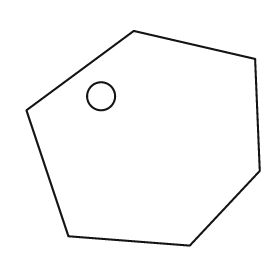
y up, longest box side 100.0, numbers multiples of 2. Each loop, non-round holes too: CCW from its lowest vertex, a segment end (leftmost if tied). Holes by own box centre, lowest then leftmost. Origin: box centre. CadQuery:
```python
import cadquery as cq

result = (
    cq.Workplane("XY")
    .moveTo(20.0, -46.0)
    .lineTo(50.0, -14.0)
    .lineTo(48.0, 34.0)
    .lineTo(-4.0, 46.0)
    .lineTo(-50.0, 12.0)
    .lineTo(-32.0, -42.0)
    .close()
    .moveTo(-18.0, 18.0)
    .circle(6.0)
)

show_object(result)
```